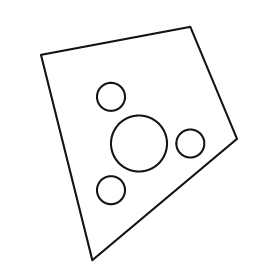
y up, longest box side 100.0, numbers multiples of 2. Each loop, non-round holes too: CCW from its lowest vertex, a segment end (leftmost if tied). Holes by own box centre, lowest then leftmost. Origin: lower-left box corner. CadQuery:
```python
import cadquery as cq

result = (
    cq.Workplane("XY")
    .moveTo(22.0, 0.0)
    .lineTo(84.0, 52.0)
    .lineTo(64.0, 100.0)
    .lineTo(0.0, 88.0)
    .close()
    .moveTo(30.0, 30.0)
    .circle(6.0)
    .moveTo(42.0, 50.0)
    .circle(12.0)
    .moveTo(64.0, 50.0)
    .circle(6.0)
    .moveTo(30.0, 70.0)
    .circle(6.0)
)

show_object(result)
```